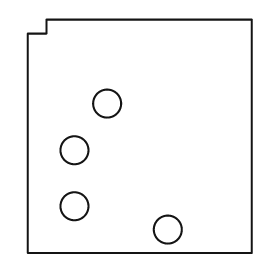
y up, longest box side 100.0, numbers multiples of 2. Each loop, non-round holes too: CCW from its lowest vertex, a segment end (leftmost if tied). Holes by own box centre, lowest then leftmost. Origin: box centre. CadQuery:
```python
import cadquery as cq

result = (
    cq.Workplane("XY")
    .moveTo(-48.0, -50.0)
    .lineTo(48.0, -50.0)
    .lineTo(48.0, 50.0)
    .lineTo(-40.0, 50.0)
    .lineTo(-40.0, 44.0)
    .lineTo(-48.0, 44.0)
    .close()
    .moveTo(12.0, -40.0)
    .circle(6.0)
    .moveTo(-28.0, -30.0)
    .circle(6.0)
    .moveTo(-28.0, -6.0)
    .circle(6.0)
    .moveTo(-14.0, 14.0)
    .circle(6.0)
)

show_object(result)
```